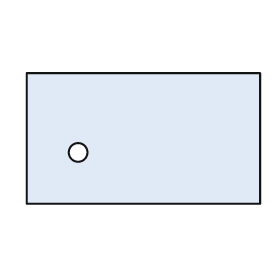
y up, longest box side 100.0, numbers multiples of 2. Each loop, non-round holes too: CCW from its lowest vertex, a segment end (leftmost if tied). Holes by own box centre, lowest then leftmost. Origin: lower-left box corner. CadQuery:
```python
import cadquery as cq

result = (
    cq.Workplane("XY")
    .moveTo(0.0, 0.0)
    .lineTo(100.0, 0.0)
    .lineTo(100.0, 56.0)
    .lineTo(0.0, 56.0)
    .close()
    .moveTo(22.0, 22.0)
    .circle(4.0)
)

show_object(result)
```